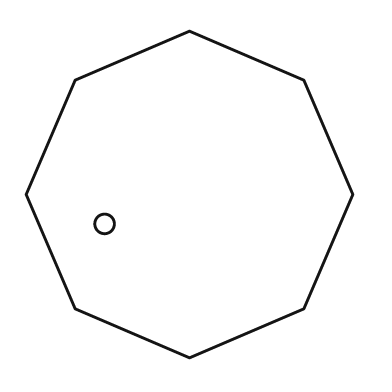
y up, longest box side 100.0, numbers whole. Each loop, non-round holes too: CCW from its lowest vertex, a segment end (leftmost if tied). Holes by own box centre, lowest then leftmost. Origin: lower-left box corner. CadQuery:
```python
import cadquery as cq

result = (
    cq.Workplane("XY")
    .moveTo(50.0, 0.0)
    .lineTo(85.0, 15.0)
    .lineTo(100.0, 50.0)
    .lineTo(85.0, 85.0)
    .lineTo(50.0, 100.0)
    .lineTo(15.0, 85.0)
    .lineTo(0.0, 50.0)
    .lineTo(15.0, 15.0)
    .close()
    .moveTo(24.0, 41.0)
    .circle(3.0)
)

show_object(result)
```